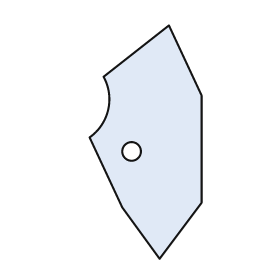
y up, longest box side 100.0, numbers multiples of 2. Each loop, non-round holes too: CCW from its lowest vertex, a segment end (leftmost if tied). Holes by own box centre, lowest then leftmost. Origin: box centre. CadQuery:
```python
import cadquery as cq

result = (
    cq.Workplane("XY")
    .moveTo(6.0, -50.0)
    .lineTo(24.0, -26.0)
    .lineTo(24.0, 20.0)
    .lineTo(10.0, 50.0)
    .lineTo(-18.0, 28.0)
    .threePointArc((-16.0, 14.0), (-24.0, 2.0))
    .lineTo(-10.0, -28.0)
    .close()
    .moveTo(-6.0, -4.0)
    .circle(4.0)
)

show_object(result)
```